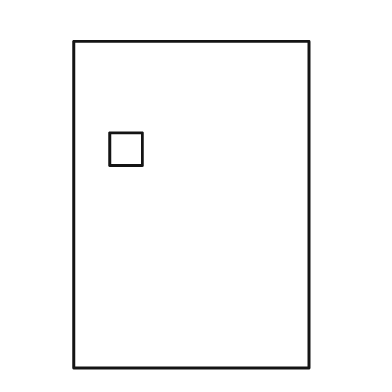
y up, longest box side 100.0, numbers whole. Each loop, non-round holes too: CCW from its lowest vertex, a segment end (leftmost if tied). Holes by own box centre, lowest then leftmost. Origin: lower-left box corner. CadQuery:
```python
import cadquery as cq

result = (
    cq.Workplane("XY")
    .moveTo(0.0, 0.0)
    .lineTo(72.0, 0.0)
    .lineTo(72.0, 100.0)
    .lineTo(0.0, 100.0)
    .close()
    .moveTo(11.0, 62.0)
    .lineTo(21.0, 62.0)
    .lineTo(21.0, 72.0)
    .lineTo(11.0, 72.0)
    .close()
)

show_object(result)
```